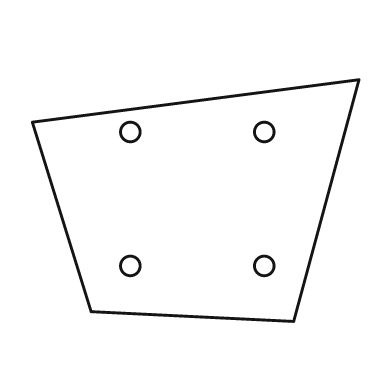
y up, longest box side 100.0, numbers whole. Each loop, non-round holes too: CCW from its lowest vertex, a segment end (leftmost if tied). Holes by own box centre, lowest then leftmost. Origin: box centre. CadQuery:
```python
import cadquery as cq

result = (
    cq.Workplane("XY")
    .moveTo(30.0, -37.0)
    .lineTo(50.0, 37.0)
    .lineTo(-50.0, 24.0)
    .lineTo(-32.0, -34.0)
    .close()
    .moveTo(-20.0, -20.0)
    .circle(3.0)
    .moveTo(21.0, -20.0)
    .circle(3.0)
    .moveTo(-20.0, 21.0)
    .circle(3.0)
    .moveTo(21.0, 21.0)
    .circle(3.0)
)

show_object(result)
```